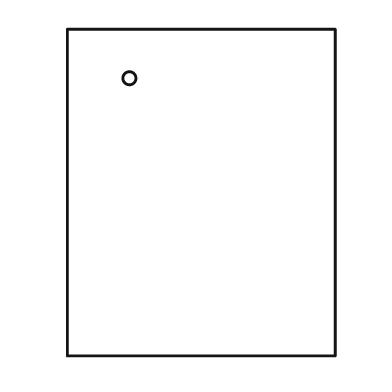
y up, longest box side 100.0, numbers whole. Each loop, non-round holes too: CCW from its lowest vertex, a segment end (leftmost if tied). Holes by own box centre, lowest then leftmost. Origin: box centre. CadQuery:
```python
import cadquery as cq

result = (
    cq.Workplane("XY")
    .moveTo(-41.0, -50.0)
    .lineTo(41.0, -50.0)
    .lineTo(41.0, 50.0)
    .lineTo(-41.0, 50.0)
    .close()
    .moveTo(-22.0, 35.0)
    .circle(2.0)
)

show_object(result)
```